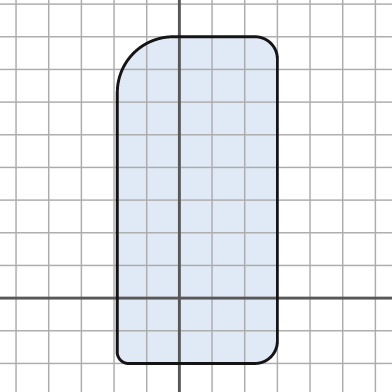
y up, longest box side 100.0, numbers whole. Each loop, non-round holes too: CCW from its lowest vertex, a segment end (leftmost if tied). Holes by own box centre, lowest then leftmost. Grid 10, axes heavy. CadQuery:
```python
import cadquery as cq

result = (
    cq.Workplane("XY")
    .moveTo(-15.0, -20.0)
    .lineTo(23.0, -20.0)
    .threePointArc((28.0, -18.0), (30.0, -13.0))
    .lineTo(30.0, 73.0)
    .threePointArc((28.0, 78.0), (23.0, 80.0))
    .lineTo(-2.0, 80.0)
    .threePointArc((-14.0, 75.0), (-19.0, 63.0))
    .lineTo(-19.0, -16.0)
    .threePointArc((-18.0, -19.0), (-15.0, -20.0))
    .close()
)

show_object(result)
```